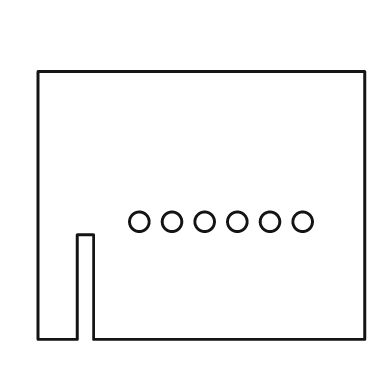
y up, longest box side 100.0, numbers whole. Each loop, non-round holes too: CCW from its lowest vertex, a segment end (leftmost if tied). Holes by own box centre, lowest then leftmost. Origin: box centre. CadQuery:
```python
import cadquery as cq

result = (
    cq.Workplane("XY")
    .moveTo(-50.0, -41.0)
    .lineTo(-38.0, -41.0)
    .lineTo(-38.0, -9.0)
    .lineTo(-33.0, -9.0)
    .lineTo(-33.0, -41.0)
    .lineTo(50.0, -41.0)
    .lineTo(50.0, 41.0)
    .lineTo(-50.0, 41.0)
    .close()
    .moveTo(-19.0, -5.0)
    .circle(3.0)
    .moveTo(-9.0, -5.0)
    .circle(3.0)
    .moveTo(1.0, -5.0)
    .circle(3.0)
    .moveTo(11.0, -5.0)
    .circle(3.0)
    .moveTo(21.0, -5.0)
    .circle(3.0)
    .moveTo(31.0, -5.0)
    .circle(3.0)
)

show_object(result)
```